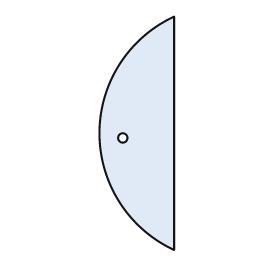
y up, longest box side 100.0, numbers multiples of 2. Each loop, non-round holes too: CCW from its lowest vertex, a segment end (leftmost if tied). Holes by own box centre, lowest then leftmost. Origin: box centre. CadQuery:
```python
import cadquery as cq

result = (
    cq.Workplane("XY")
    .moveTo(16.0, -50.0)
    .lineTo(16.0, 50.0)
    .threePointArc((-16.0, 0.0), (16.0, -50.0))
    .close()
    .moveTo(-6.0, -2.0)
    .circle(2.0)
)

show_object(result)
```